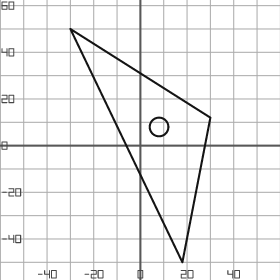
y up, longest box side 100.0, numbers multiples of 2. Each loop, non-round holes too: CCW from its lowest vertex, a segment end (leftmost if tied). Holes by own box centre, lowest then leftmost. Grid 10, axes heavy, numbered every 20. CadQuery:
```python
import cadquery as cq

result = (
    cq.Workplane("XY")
    .moveTo(18.0, -50.0)
    .lineTo(30.0, 12.0)
    .lineTo(-30.0, 50.0)
    .close()
    .moveTo(8.0, 8.0)
    .circle(4.0)
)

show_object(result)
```